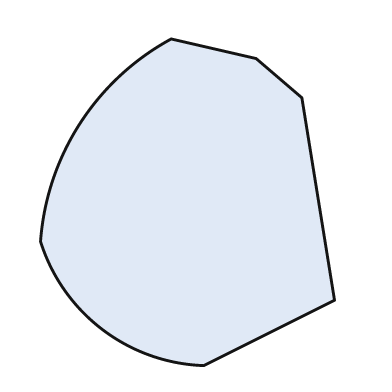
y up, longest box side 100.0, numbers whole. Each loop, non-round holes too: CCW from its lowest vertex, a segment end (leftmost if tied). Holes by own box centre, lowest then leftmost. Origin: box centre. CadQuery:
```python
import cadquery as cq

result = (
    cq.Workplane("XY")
    .moveTo(5.0, -50.0)
    .lineTo(45.0, -30.0)
    .lineTo(35.0, 32.0)
    .lineTo(21.0, 44.0)
    .lineTo(-5.0, 50.0)
    .threePointArc((-33.0, 24.0), (-45.0, -12.0))
    .threePointArc((-26.0, -39.0), (5.0, -50.0))
    .close()
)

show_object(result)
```